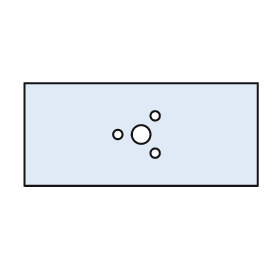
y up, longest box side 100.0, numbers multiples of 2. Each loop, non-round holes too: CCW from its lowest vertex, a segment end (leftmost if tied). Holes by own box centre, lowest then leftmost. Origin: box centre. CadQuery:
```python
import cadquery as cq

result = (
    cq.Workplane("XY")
    .moveTo(-50.0, -22.0)
    .lineTo(50.0, -22.0)
    .lineTo(50.0, 22.0)
    .lineTo(-50.0, 22.0)
    .close()
    .moveTo(6.0, -8.0)
    .circle(2.0)
    .moveTo(-10.0, 0.0)
    .circle(2.0)
    .moveTo(0.0, 0.0)
    .circle(4.0)
    .moveTo(6.0, 8.0)
    .circle(2.0)
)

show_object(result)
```